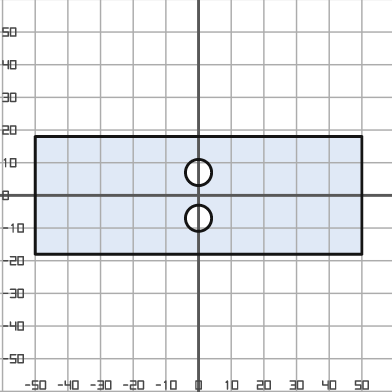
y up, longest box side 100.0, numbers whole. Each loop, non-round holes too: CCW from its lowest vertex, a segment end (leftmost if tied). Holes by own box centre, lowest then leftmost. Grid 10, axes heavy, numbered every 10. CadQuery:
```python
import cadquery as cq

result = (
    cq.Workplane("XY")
    .moveTo(-50.0, -18.0)
    .lineTo(50.0, -18.0)
    .lineTo(50.0, 18.0)
    .lineTo(-50.0, 18.0)
    .close()
    .moveTo(0.0, -7.0)
    .circle(4.0)
    .moveTo(0.0, 7.0)
    .circle(4.0)
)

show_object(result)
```